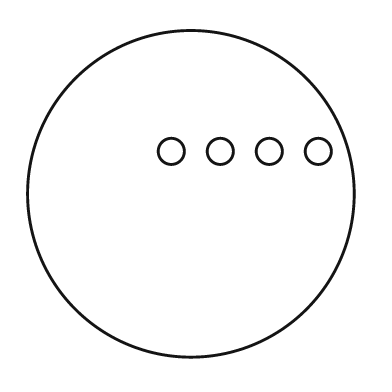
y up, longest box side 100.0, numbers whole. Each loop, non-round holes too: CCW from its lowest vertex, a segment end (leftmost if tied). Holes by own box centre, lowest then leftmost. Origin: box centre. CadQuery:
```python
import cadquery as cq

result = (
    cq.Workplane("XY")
    .moveTo(0.0, 0.0)
    .circle(50.0)
    .moveTo(-6.0, 13.0)
    .circle(4.0)
    .moveTo(9.0, 13.0)
    .circle(4.0)
    .moveTo(24.0, 13.0)
    .circle(4.0)
    .moveTo(39.0, 13.0)
    .circle(4.0)
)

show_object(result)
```